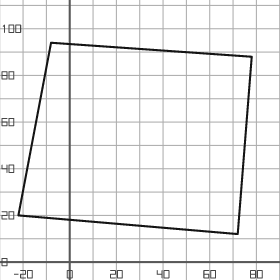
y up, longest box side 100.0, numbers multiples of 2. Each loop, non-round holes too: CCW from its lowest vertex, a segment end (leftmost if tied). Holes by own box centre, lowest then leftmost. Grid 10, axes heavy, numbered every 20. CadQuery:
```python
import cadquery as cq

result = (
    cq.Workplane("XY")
    .moveTo(72.0, 12.0)
    .lineTo(78.0, 88.0)
    .lineTo(-8.0, 94.0)
    .lineTo(-22.0, 20.0)
    .close()
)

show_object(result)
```